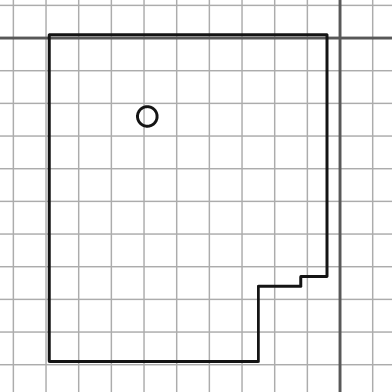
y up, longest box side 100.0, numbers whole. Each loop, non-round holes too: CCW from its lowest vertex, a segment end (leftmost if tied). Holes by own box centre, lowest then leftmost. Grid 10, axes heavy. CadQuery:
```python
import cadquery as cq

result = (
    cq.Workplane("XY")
    .moveTo(-89.0, -99.0)
    .lineTo(-25.0, -99.0)
    .lineTo(-25.0, -76.0)
    .lineTo(-12.0, -76.0)
    .lineTo(-12.0, -73.0)
    .lineTo(-4.0, -73.0)
    .lineTo(-4.0, 1.0)
    .lineTo(-89.0, 1.0)
    .close()
    .moveTo(-59.0, -24.0)
    .circle(3.0)
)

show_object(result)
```